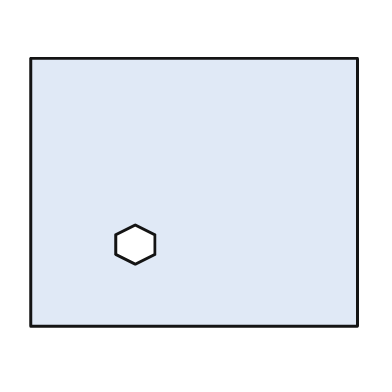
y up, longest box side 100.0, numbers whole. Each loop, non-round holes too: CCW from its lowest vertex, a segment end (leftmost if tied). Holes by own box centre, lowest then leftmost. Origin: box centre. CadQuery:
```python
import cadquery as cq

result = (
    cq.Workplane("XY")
    .moveTo(-50.0, -41.0)
    .lineTo(50.0, -41.0)
    .lineTo(50.0, 41.0)
    .lineTo(-50.0, 41.0)
    .close()
    .moveTo(-18.0, -22.0)
    .lineTo(-12.0, -19.0)
    .lineTo(-12.0, -13.0)
    .lineTo(-18.0, -10.0)
    .lineTo(-24.0, -13.0)
    .lineTo(-24.0, -19.0)
    .close()
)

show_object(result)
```